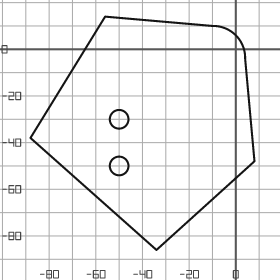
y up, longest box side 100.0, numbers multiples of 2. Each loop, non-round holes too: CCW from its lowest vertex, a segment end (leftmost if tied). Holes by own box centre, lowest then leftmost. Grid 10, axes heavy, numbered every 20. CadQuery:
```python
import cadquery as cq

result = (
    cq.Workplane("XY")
    .moveTo(-34.0, -86.0)
    .lineTo(8.0, -48.0)
    .lineTo(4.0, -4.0)
    .threePointArc((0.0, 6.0), (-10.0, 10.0))
    .lineTo(-56.0, 14.0)
    .lineTo(-88.0, -38.0)
    .close()
    .moveTo(-50.0, -50.0)
    .circle(4.0)
    .moveTo(-50.0, -30.0)
    .circle(4.0)
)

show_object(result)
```